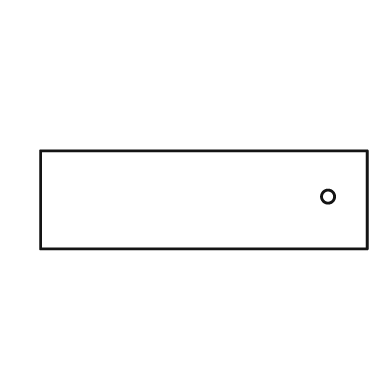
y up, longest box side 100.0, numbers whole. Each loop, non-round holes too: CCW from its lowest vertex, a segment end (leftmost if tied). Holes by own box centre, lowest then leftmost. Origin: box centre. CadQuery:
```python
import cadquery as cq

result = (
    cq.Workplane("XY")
    .moveTo(-50.0, -15.0)
    .lineTo(50.0, -15.0)
    .lineTo(50.0, 15.0)
    .lineTo(-50.0, 15.0)
    .close()
    .moveTo(38.0, 1.0)
    .circle(2.0)
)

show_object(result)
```